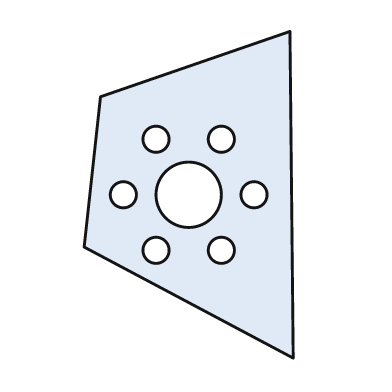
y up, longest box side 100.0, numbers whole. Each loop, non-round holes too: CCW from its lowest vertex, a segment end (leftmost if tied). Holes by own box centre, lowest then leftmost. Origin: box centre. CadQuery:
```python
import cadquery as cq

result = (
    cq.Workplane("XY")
    .moveTo(32.0, -50.0)
    .lineTo(31.0, 50.0)
    .lineTo(-27.0, 30.0)
    .lineTo(-32.0, -16.0)
    .close()
    .moveTo(-10.0, -17.0)
    .circle(4.0)
    .moveTo(10.0, -17.0)
    .circle(4.0)
    .moveTo(-20.0, 0.0)
    .circle(4.0)
    .moveTo(0.0, 0.0)
    .circle(10.0)
    .moveTo(20.0, 0.0)
    .circle(4.0)
    .moveTo(-10.0, 17.0)
    .circle(4.0)
    .moveTo(10.0, 17.0)
    .circle(4.0)
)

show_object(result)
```